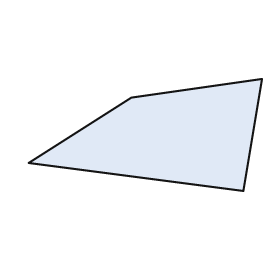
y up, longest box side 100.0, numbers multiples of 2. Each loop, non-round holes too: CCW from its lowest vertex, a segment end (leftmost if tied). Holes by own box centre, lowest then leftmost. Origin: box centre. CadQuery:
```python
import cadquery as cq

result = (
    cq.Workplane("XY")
    .moveTo(42.0, -24.0)
    .lineTo(50.0, 24.0)
    .lineTo(-6.0, 16.0)
    .lineTo(-50.0, -12.0)
    .close()
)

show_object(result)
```